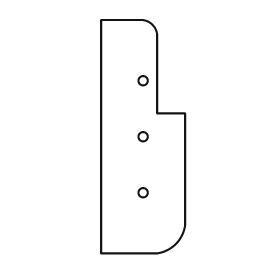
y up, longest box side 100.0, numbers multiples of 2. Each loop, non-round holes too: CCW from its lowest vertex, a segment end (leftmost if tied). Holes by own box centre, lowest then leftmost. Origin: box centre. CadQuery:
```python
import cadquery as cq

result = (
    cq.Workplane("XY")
    .moveTo(-18.0, -50.0)
    .lineTo(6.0, -50.0)
    .threePointArc((14.0, -46.0), (18.0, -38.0))
    .lineTo(18.0, 10.0)
    .lineTo(6.0, 10.0)
    .lineTo(6.0, 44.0)
    .threePointArc((4.0, 48.0), (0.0, 50.0))
    .lineTo(-18.0, 50.0)
    .close()
    .moveTo(0.0, -24.0)
    .circle(2.0)
    .moveTo(0.0, 0.0)
    .circle(2.0)
    .moveTo(0.0, 24.0)
    .circle(2.0)
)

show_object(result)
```